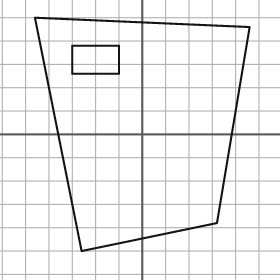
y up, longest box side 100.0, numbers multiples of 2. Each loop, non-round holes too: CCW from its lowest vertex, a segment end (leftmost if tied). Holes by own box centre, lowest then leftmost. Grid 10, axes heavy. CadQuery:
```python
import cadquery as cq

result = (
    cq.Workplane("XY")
    .moveTo(-26.0, -50.0)
    .lineTo(32.0, -38.0)
    .lineTo(46.0, 46.0)
    .lineTo(-46.0, 50.0)
    .close()
    .moveTo(-30.0, 26.0)
    .lineTo(-10.0, 26.0)
    .lineTo(-10.0, 38.0)
    .lineTo(-30.0, 38.0)
    .close()
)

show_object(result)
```